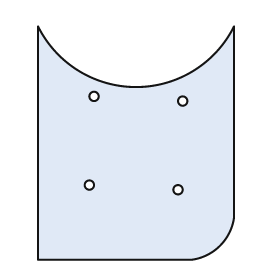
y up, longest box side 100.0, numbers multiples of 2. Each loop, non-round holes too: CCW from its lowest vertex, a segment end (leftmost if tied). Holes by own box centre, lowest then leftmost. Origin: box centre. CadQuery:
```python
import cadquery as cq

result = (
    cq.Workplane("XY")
    .moveTo(-42.0, -50.0)
    .lineTo(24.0, -50.0)
    .threePointArc((36.0, -44.0), (42.0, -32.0))
    .lineTo(42.0, 50.0)
    .threePointArc((0.0, 24.0), (-42.0, 50.0))
    .close()
    .moveTo(18.0, -20.0)
    .circle(2.0)
    .moveTo(-20.0, -18.0)
    .circle(2.0)
    .moveTo(20.0, 18.0)
    .circle(2.0)
    .moveTo(-18.0, 20.0)
    .circle(2.0)
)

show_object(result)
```